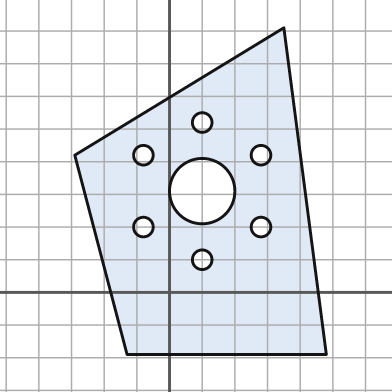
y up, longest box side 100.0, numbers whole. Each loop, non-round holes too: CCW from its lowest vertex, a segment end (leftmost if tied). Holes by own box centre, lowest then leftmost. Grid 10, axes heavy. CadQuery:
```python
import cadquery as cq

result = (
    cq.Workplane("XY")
    .moveTo(-13.0, -19.0)
    .lineTo(48.0, -19.0)
    .lineTo(35.0, 81.0)
    .lineTo(-29.0, 42.0)
    .close()
    .moveTo(10.0, 10.0)
    .circle(3.0)
    .moveTo(-8.0, 20.0)
    .circle(3.0)
    .moveTo(28.0, 20.0)
    .circle(3.0)
    .moveTo(10.0, 31.0)
    .circle(10.0)
    .moveTo(-8.0, 42.0)
    .circle(3.0)
    .moveTo(28.0, 42.0)
    .circle(3.0)
    .moveTo(10.0, 52.0)
    .circle(3.0)
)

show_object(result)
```